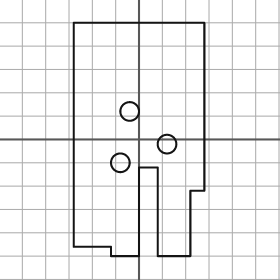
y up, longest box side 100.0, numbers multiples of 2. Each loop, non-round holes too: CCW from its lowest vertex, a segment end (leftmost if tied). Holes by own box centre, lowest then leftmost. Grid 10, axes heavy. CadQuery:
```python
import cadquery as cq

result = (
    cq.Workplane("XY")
    .moveTo(-12.0, -50.0)
    .lineTo(0.0, -50.0)
    .lineTo(0.0, -12.0)
    .lineTo(8.0, -12.0)
    .lineTo(8.0, -50.0)
    .lineTo(22.0, -50.0)
    .lineTo(22.0, -22.0)
    .lineTo(28.0, -22.0)
    .lineTo(28.0, 50.0)
    .lineTo(-28.0, 50.0)
    .lineTo(-28.0, -46.0)
    .lineTo(-12.0, -46.0)
    .close()
    .moveTo(-8.0, -10.0)
    .circle(4.0)
    .moveTo(12.0, -2.0)
    .circle(4.0)
    .moveTo(-4.0, 12.0)
    .circle(4.0)
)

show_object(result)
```